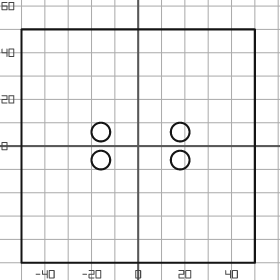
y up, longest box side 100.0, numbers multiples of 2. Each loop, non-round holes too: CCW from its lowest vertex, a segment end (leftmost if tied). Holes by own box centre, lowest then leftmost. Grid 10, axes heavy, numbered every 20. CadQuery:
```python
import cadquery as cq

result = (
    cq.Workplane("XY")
    .moveTo(-50.0, -50.0)
    .lineTo(50.0, -50.0)
    .lineTo(50.0, 50.0)
    .lineTo(-50.0, 50.0)
    .close()
    .moveTo(-16.0, -6.0)
    .circle(4.0)
    .moveTo(18.0, -6.0)
    .circle(4.0)
    .moveTo(-16.0, 6.0)
    .circle(4.0)
    .moveTo(18.0, 6.0)
    .circle(4.0)
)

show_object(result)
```